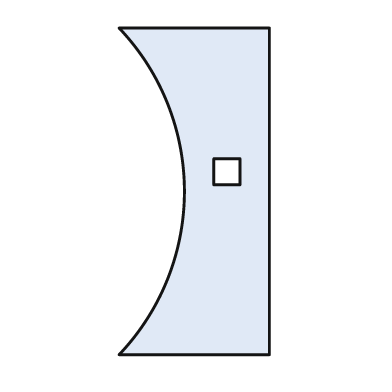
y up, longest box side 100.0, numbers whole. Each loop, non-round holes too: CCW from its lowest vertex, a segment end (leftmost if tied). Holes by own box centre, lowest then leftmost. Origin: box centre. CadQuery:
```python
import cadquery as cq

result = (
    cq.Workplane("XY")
    .moveTo(-23.0, -50.0)
    .lineTo(23.0, -50.0)
    .lineTo(23.0, 50.0)
    .lineTo(-23.0, 50.0)
    .threePointArc((-3.0, 0.0), (-23.0, -50.0))
    .close()
    .moveTo(6.0, 2.0)
    .lineTo(14.0, 2.0)
    .lineTo(14.0, 10.0)
    .lineTo(6.0, 10.0)
    .close()
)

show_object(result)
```